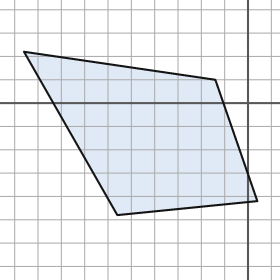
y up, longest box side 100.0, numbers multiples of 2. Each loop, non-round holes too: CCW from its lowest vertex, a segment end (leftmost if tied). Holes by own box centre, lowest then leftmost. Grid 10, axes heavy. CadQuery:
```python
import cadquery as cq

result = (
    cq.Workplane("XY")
    .moveTo(-56.0, -48.0)
    .lineTo(4.0, -42.0)
    .lineTo(-14.0, 10.0)
    .lineTo(-96.0, 22.0)
    .close()
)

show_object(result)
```